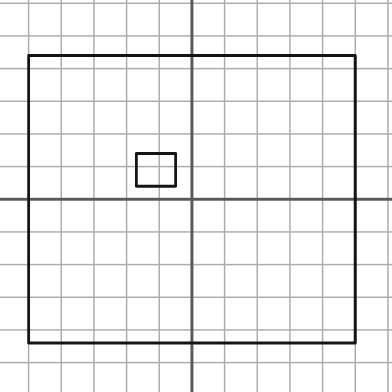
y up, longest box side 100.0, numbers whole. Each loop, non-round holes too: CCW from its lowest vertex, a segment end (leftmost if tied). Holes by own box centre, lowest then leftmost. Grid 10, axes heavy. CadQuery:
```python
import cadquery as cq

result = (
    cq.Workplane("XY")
    .moveTo(-50.0, -44.0)
    .lineTo(50.0, -44.0)
    .lineTo(50.0, 44.0)
    .lineTo(-50.0, 44.0)
    .close()
    .moveTo(-17.0, 4.0)
    .lineTo(-5.0, 4.0)
    .lineTo(-5.0, 14.0)
    .lineTo(-17.0, 14.0)
    .close()
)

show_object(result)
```